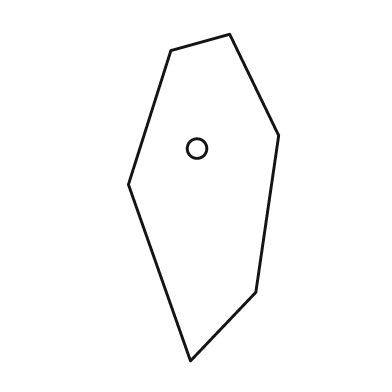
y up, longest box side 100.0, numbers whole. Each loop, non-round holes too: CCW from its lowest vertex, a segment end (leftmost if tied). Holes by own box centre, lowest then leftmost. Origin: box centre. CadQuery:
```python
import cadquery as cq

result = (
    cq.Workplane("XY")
    .moveTo(-4.0, -50.0)
    .lineTo(16.0, -29.0)
    .lineTo(23.0, 19.0)
    .lineTo(8.0, 50.0)
    .lineTo(-10.0, 45.0)
    .lineTo(-23.0, 4.0)
    .close()
    .moveTo(-2.0, 15.0)
    .circle(3.0)
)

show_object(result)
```